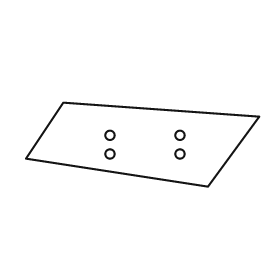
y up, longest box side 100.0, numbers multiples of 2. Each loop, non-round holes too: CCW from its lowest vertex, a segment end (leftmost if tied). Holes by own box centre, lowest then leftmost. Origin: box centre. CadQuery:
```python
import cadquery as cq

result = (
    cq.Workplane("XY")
    .moveTo(28.0, -18.0)
    .lineTo(50.0, 12.0)
    .lineTo(-34.0, 18.0)
    .lineTo(-50.0, -6.0)
    .close()
    .moveTo(-14.0, -4.0)
    .circle(2.0)
    .moveTo(16.0, -4.0)
    .circle(2.0)
    .moveTo(-14.0, 4.0)
    .circle(2.0)
    .moveTo(16.0, 4.0)
    .circle(2.0)
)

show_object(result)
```